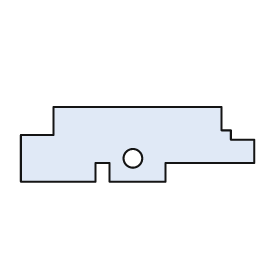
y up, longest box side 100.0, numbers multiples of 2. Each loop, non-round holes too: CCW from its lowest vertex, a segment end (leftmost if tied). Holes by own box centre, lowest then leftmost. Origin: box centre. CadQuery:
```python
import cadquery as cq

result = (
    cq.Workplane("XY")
    .moveTo(-50.0, -16.0)
    .lineTo(-18.0, -16.0)
    .lineTo(-18.0, -8.0)
    .lineTo(-12.0, -8.0)
    .lineTo(-12.0, -16.0)
    .lineTo(12.0, -16.0)
    .lineTo(12.0, -8.0)
    .lineTo(50.0, -8.0)
    .lineTo(50.0, 2.0)
    .lineTo(40.0, 2.0)
    .lineTo(40.0, 6.0)
    .lineTo(36.0, 6.0)
    .lineTo(36.0, 16.0)
    .lineTo(-36.0, 16.0)
    .lineTo(-36.0, 4.0)
    .lineTo(-50.0, 4.0)
    .close()
    .moveTo(-2.0, -6.0)
    .circle(4.0)
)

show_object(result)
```